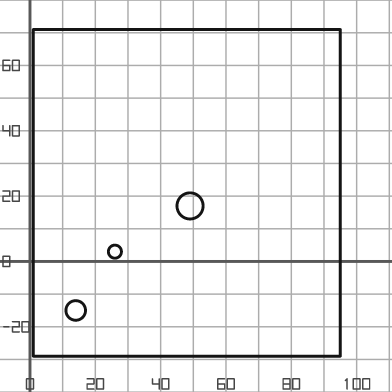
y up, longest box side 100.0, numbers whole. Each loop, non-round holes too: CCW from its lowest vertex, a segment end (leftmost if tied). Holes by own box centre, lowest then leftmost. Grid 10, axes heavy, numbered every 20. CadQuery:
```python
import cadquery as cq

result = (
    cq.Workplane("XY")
    .moveTo(1.0, -29.0)
    .lineTo(95.0, -29.0)
    .lineTo(95.0, 71.0)
    .lineTo(1.0, 71.0)
    .close()
    .moveTo(14.0, -15.0)
    .circle(3.0)
    .moveTo(26.0, 3.0)
    .circle(2.0)
    .moveTo(49.0, 17.0)
    .circle(4.0)
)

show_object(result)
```